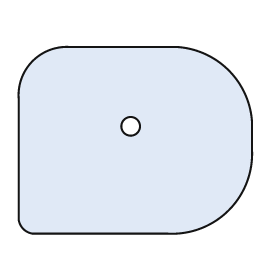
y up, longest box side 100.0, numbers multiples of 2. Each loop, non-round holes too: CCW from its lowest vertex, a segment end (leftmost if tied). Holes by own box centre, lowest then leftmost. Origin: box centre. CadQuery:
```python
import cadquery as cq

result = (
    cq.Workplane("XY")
    .moveTo(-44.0, -40.0)
    .lineTo(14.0, -40.0)
    .threePointArc((40.0, -30.0), (50.0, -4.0))
    .lineTo(50.0, 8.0)
    .threePointArc((40.0, 30.0), (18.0, 40.0))
    .lineTo(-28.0, 40.0)
    .threePointArc((-44.0, 34.0), (-50.0, 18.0))
    .lineTo(-50.0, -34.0)
    .threePointArc((-48.0, -38.0), (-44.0, -40.0))
    .close()
    .moveTo(-2.0, 6.0)
    .circle(4.0)
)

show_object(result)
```